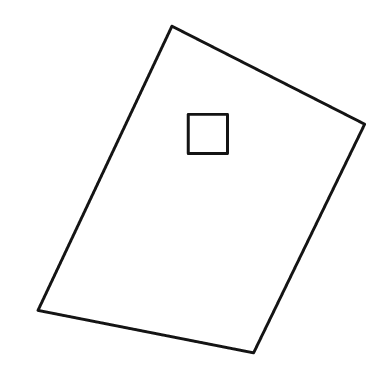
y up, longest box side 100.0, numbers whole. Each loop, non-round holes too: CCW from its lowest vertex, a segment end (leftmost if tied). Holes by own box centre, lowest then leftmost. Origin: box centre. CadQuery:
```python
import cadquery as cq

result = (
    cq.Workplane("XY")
    .moveTo(16.0, -50.0)
    .lineTo(50.0, 20.0)
    .lineTo(-9.0, 50.0)
    .lineTo(-50.0, -37.0)
    .close()
    .moveTo(-4.0, 11.0)
    .lineTo(8.0, 11.0)
    .lineTo(8.0, 23.0)
    .lineTo(-4.0, 23.0)
    .close()
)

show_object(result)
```